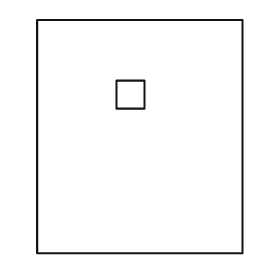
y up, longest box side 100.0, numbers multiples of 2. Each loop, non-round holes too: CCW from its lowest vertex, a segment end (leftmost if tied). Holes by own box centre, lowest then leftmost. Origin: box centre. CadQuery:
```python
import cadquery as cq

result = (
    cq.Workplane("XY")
    .moveTo(-44.0, -50.0)
    .lineTo(44.0, -50.0)
    .lineTo(44.0, 50.0)
    .lineTo(-44.0, 50.0)
    .close()
    .moveTo(-10.0, 12.0)
    .lineTo(2.0, 12.0)
    .lineTo(2.0, 24.0)
    .lineTo(-10.0, 24.0)
    .close()
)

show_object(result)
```